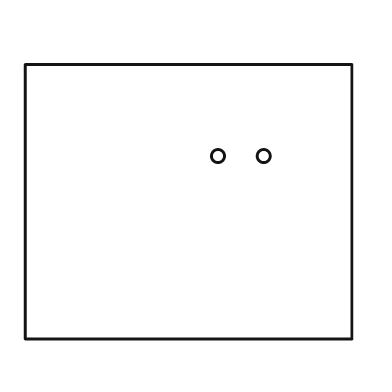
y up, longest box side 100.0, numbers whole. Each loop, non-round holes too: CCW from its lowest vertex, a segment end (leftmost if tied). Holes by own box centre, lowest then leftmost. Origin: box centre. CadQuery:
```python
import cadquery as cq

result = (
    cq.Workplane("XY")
    .moveTo(-50.0, -42.0)
    .lineTo(50.0, -42.0)
    .lineTo(50.0, 42.0)
    .lineTo(-50.0, 42.0)
    .close()
    .moveTo(9.0, 14.0)
    .circle(2.0)
    .moveTo(23.0, 14.0)
    .circle(2.0)
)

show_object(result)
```